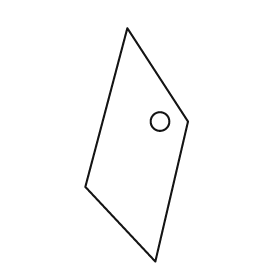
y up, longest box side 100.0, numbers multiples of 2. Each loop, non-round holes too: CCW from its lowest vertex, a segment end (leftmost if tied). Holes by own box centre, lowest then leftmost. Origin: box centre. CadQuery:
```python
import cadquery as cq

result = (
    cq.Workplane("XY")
    .moveTo(8.0, -50.0)
    .lineTo(22.0, 10.0)
    .lineTo(-4.0, 50.0)
    .lineTo(-22.0, -18.0)
    .close()
    .moveTo(10.0, 10.0)
    .circle(4.0)
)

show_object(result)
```